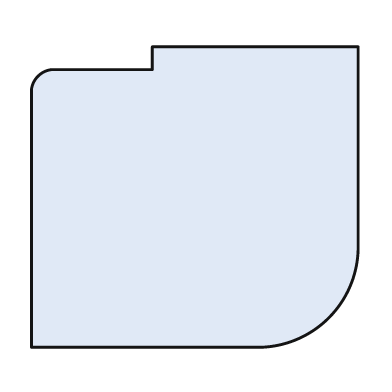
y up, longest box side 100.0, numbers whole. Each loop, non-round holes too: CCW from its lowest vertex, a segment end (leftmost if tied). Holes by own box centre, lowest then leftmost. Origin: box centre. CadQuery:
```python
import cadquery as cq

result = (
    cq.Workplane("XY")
    .moveTo(-50.0, -46.0)
    .lineTo(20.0, -46.0)
    .threePointArc((41.0, -37.0), (50.0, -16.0))
    .lineTo(50.0, 46.0)
    .lineTo(-13.0, 46.0)
    .lineTo(-13.0, 39.0)
    .lineTo(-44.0, 39.0)
    .threePointArc((-48.0, 37.0), (-50.0, 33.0))
    .close()
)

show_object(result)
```